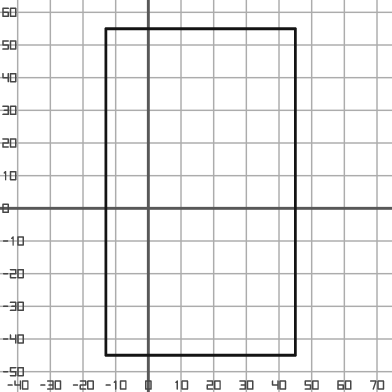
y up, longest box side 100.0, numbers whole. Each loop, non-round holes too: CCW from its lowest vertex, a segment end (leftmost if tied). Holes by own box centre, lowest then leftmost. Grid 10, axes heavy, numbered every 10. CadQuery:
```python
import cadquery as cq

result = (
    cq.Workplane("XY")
    .moveTo(-13.0, -45.0)
    .lineTo(45.0, -45.0)
    .lineTo(45.0, 55.0)
    .lineTo(-13.0, 55.0)
    .close()
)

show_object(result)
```